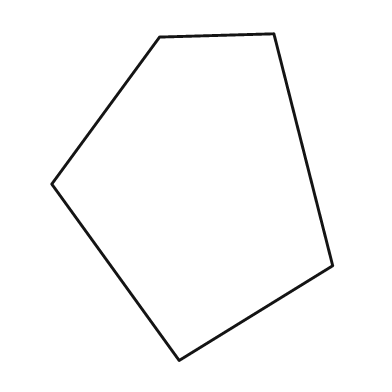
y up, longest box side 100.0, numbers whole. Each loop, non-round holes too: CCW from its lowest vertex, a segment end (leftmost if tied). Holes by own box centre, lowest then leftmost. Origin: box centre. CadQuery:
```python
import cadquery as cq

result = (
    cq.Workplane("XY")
    .moveTo(-4.0, -50.0)
    .lineTo(43.0, -21.0)
    .lineTo(25.0, 50.0)
    .lineTo(-10.0, 49.0)
    .lineTo(-43.0, 4.0)
    .close()
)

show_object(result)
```